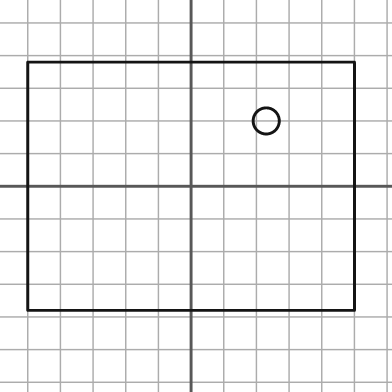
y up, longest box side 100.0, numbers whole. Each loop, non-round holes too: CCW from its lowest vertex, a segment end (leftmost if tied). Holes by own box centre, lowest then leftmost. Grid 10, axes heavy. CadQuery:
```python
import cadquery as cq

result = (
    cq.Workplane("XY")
    .moveTo(-50.0, -38.0)
    .lineTo(50.0, -38.0)
    .lineTo(50.0, 38.0)
    .lineTo(-50.0, 38.0)
    .close()
    .moveTo(23.0, 20.0)
    .circle(4.0)
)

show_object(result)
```